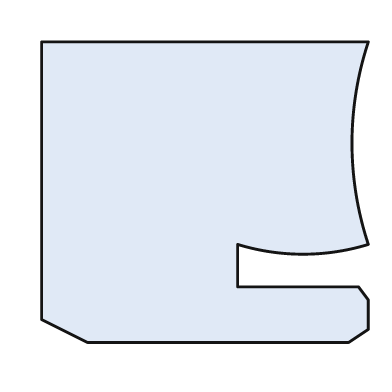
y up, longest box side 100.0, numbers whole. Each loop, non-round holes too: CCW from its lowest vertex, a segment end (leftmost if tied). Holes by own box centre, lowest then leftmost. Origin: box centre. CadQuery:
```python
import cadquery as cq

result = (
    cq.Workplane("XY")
    .moveTo(-36.0, -46.0)
    .lineTo(44.0, -46.0)
    .lineTo(50.0, -42.0)
    .lineTo(50.0, -33.0)
    .lineTo(47.0, -29.0)
    .lineTo(10.0, -29.0)
    .lineTo(10.0, -16.0)
    .threePointArc((30.0, -19.0), (50.0, -16.0))
    .threePointArc((45.0, 15.0), (50.0, 46.0))
    .lineTo(-50.0, 46.0)
    .lineTo(-50.0, -39.0)
    .close()
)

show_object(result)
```